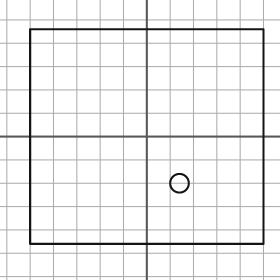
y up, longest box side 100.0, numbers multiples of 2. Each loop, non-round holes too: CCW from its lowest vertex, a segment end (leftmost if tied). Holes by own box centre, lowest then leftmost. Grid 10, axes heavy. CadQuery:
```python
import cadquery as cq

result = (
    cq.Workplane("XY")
    .moveTo(-50.0, -46.0)
    .lineTo(50.0, -46.0)
    .lineTo(50.0, 46.0)
    .lineTo(-50.0, 46.0)
    .close()
    .moveTo(14.0, -20.0)
    .circle(4.0)
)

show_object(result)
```